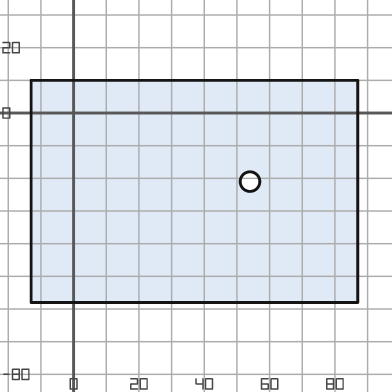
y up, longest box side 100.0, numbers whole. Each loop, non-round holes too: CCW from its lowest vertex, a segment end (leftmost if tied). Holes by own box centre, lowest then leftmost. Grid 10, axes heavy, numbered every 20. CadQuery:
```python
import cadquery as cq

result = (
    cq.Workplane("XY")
    .moveTo(-13.0, -58.0)
    .lineTo(87.0, -58.0)
    .lineTo(87.0, 10.0)
    .lineTo(-13.0, 10.0)
    .close()
    .moveTo(54.0, -21.0)
    .circle(3.0)
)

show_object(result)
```